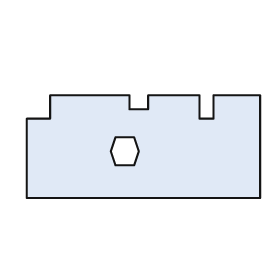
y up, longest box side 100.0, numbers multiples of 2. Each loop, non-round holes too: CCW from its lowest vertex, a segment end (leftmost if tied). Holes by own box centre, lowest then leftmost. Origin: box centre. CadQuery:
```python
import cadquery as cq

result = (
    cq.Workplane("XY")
    .moveTo(-50.0, -22.0)
    .lineTo(50.0, -22.0)
    .lineTo(50.0, 22.0)
    .lineTo(30.0, 22.0)
    .lineTo(30.0, 12.0)
    .lineTo(24.0, 12.0)
    .lineTo(24.0, 22.0)
    .lineTo(2.0, 22.0)
    .lineTo(2.0, 16.0)
    .lineTo(-6.0, 16.0)
    .lineTo(-6.0, 22.0)
    .lineTo(-40.0, 22.0)
    .lineTo(-40.0, 12.0)
    .lineTo(-50.0, 12.0)
    .close()
    .moveTo(-12.0, -8.0)
    .lineTo(-4.0, -8.0)
    .lineTo(-2.0, -2.0)
    .lineTo(-4.0, 4.0)
    .lineTo(-12.0, 4.0)
    .lineTo(-14.0, -2.0)
    .close()
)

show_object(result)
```